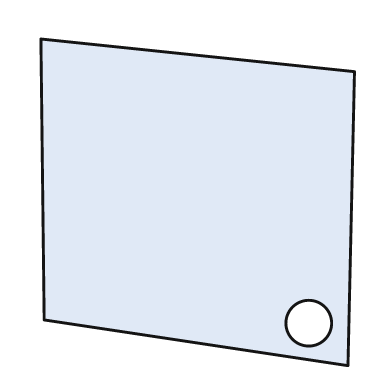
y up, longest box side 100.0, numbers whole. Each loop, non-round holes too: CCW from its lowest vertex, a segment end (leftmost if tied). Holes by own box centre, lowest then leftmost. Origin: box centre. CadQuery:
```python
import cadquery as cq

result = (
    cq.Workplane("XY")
    .moveTo(46.0, -50.0)
    .lineTo(48.0, 40.0)
    .lineTo(-48.0, 50.0)
    .lineTo(-47.0, -36.0)
    .close()
    .moveTo(34.0, -37.0)
    .circle(7.0)
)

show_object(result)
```